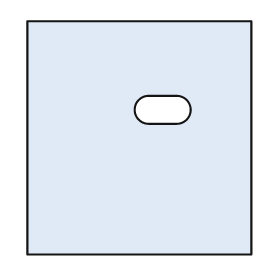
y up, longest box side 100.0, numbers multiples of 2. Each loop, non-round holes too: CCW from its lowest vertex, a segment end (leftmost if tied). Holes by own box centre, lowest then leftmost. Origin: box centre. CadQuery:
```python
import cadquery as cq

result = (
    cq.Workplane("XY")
    .moveTo(-48.0, -50.0)
    .lineTo(48.0, -50.0)
    .lineTo(48.0, 50.0)
    .lineTo(-48.0, 50.0)
    .close()
    .moveTo(4.0, 6.0)
    .lineTo(16.0, 6.0)
    .threePointArc((22.0, 12.0), (16.0, 18.0))
    .lineTo(4.0, 18.0)
    .threePointArc((-2.0, 12.0), (4.0, 6.0))
    .close()
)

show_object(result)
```